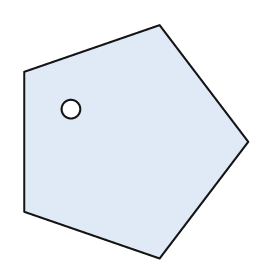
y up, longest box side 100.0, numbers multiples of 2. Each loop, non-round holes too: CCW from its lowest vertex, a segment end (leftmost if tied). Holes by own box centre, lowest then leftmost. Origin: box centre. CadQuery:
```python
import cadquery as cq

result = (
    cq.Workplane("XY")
    .moveTo(10.0, -50.0)
    .lineTo(48.0, 0.0)
    .lineTo(10.0, 50.0)
    .lineTo(-48.0, 30.0)
    .lineTo(-48.0, -30.0)
    .close()
    .moveTo(-28.0, 14.0)
    .circle(4.0)
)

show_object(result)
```